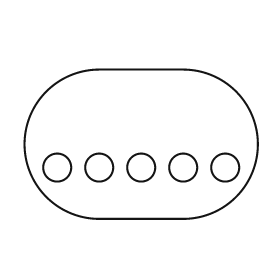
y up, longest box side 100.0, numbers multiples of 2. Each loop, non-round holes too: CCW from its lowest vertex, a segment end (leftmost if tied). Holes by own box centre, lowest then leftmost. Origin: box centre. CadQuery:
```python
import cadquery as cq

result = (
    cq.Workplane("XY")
    .moveTo(-18.0, -32.0)
    .lineTo(18.0, -32.0)
    .threePointArc((50.0, 0.0), (18.0, 32.0))
    .lineTo(-18.0, 32.0)
    .threePointArc((-50.0, 0.0), (-18.0, -32.0))
    .close()
    .moveTo(-36.0, -10.0)
    .circle(6.0)
    .moveTo(-18.0, -10.0)
    .circle(6.0)
    .moveTo(0.0, -10.0)
    .circle(6.0)
    .moveTo(18.0, -10.0)
    .circle(6.0)
    .moveTo(36.0, -10.0)
    .circle(6.0)
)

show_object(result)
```